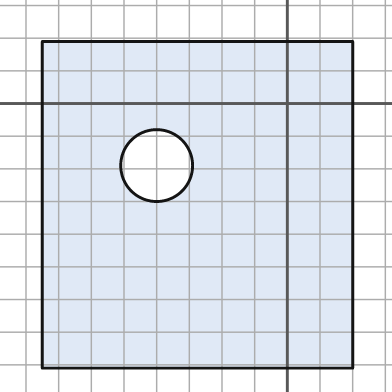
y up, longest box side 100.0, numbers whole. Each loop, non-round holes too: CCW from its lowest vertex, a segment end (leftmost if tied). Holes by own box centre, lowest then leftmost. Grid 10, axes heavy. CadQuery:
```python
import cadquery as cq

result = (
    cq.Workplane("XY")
    .moveTo(-75.0, -81.0)
    .lineTo(20.0, -81.0)
    .lineTo(20.0, 19.0)
    .lineTo(-75.0, 19.0)
    .close()
    .moveTo(-40.0, -19.0)
    .circle(11.0)
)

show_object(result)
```